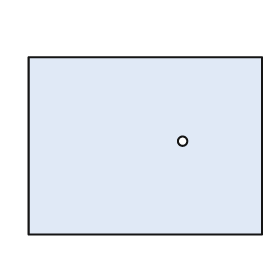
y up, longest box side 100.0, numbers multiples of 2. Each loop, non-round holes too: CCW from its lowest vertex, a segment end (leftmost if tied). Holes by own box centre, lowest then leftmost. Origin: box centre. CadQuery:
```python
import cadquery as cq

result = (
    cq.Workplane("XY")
    .moveTo(-50.0, -38.0)
    .lineTo(50.0, -38.0)
    .lineTo(50.0, 38.0)
    .lineTo(-50.0, 38.0)
    .close()
    .moveTo(16.0, 2.0)
    .circle(2.0)
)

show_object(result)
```